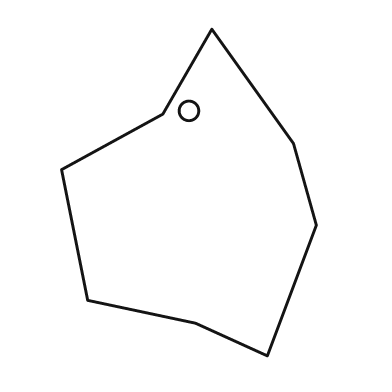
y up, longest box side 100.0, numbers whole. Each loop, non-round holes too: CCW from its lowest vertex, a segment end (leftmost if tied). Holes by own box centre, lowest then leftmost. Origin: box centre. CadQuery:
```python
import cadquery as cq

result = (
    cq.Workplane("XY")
    .moveTo(24.0, -50.0)
    .lineTo(39.0, -10.0)
    .lineTo(32.0, 15.0)
    .lineTo(7.0, 50.0)
    .lineTo(-8.0, 24.0)
    .lineTo(-39.0, 7.0)
    .lineTo(-31.0, -33.0)
    .lineTo(2.0, -40.0)
    .close()
    .moveTo(0.0, 25.0)
    .circle(3.0)
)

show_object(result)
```